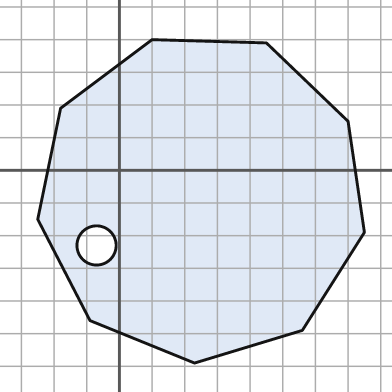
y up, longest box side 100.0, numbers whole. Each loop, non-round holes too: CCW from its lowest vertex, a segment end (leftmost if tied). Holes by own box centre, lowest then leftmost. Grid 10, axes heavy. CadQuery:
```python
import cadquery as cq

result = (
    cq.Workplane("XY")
    .moveTo(23.0, -59.0)
    .lineTo(56.0, -49.0)
    .lineTo(75.0, -19.0)
    .lineTo(70.0, 15.0)
    .lineTo(45.0, 39.0)
    .lineTo(10.0, 40.0)
    .lineTo(-18.0, 19.0)
    .lineTo(-25.0, -15.0)
    .lineTo(-9.0, -46.0)
    .close()
    .moveTo(-7.0, -23.0)
    .circle(6.0)
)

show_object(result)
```